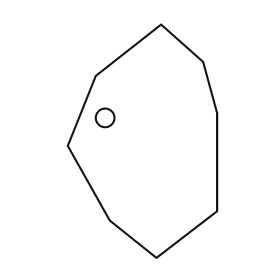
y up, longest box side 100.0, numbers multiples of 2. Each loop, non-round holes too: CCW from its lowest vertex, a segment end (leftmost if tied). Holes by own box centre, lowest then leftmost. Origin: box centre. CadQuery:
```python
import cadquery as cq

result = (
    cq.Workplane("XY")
    .moveTo(6.0, -50.0)
    .lineTo(32.0, -30.0)
    .lineTo(32.0, 12.0)
    .lineTo(26.0, 34.0)
    .lineTo(8.0, 50.0)
    .lineTo(-20.0, 28.0)
    .lineTo(-32.0, -2.0)
    .lineTo(-14.0, -34.0)
    .close()
    .moveTo(-16.0, 10.0)
    .circle(4.0)
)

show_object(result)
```